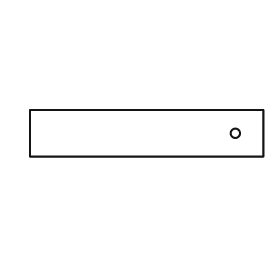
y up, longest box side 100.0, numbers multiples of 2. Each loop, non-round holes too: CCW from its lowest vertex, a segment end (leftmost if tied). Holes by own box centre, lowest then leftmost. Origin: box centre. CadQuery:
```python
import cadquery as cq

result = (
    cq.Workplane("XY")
    .moveTo(-50.0, -10.0)
    .lineTo(50.0, -10.0)
    .lineTo(50.0, 10.0)
    .lineTo(-50.0, 10.0)
    .close()
    .moveTo(38.0, 0.0)
    .circle(2.0)
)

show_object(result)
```